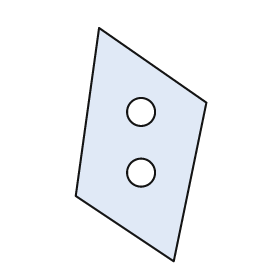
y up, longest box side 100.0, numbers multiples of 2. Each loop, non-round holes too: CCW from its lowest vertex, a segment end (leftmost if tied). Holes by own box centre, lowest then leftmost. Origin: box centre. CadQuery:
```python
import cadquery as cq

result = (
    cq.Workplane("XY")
    .moveTo(14.0, -50.0)
    .lineTo(28.0, 18.0)
    .lineTo(-18.0, 50.0)
    .lineTo(-28.0, -22.0)
    .close()
    .moveTo(0.0, -12.0)
    .circle(6.0)
    .moveTo(0.0, 14.0)
    .circle(6.0)
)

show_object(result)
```